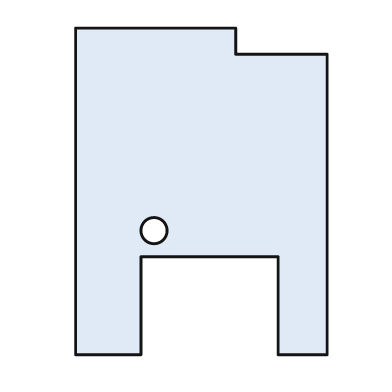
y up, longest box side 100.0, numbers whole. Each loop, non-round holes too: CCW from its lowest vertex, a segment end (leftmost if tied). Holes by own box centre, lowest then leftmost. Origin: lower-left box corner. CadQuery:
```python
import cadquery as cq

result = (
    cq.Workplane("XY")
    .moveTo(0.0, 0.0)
    .lineTo(20.0, 0.0)
    .lineTo(20.0, 30.0)
    .lineTo(62.0, 30.0)
    .lineTo(62.0, 0.0)
    .lineTo(77.0, 0.0)
    .lineTo(77.0, 92.0)
    .lineTo(49.0, 92.0)
    .lineTo(49.0, 100.0)
    .lineTo(0.0, 100.0)
    .close()
    .moveTo(24.0, 38.0)
    .circle(4.0)
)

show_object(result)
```